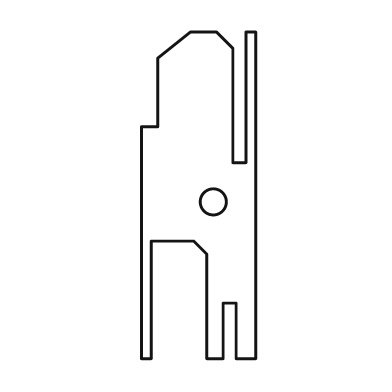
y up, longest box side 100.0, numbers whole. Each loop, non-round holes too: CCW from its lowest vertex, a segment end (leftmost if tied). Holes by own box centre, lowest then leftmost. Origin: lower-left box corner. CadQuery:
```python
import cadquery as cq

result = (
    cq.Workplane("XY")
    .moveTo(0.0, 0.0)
    .lineTo(3.0, 0.0)
    .lineTo(3.0, 36.0)
    .lineTo(16.0, 36.0)
    .lineTo(20.0, 32.0)
    .lineTo(20.0, 0.0)
    .lineTo(25.0, 0.0)
    .lineTo(25.0, 17.0)
    .lineTo(29.0, 17.0)
    .lineTo(29.0, 0.0)
    .lineTo(35.0, 0.0)
    .lineTo(35.0, 100.0)
    .lineTo(32.0, 100.0)
    .lineTo(32.0, 60.0)
    .lineTo(28.0, 60.0)
    .lineTo(28.0, 95.0)
    .lineTo(23.0, 100.0)
    .lineTo(15.0, 100.0)
    .lineTo(5.0, 92.0)
    .lineTo(5.0, 71.0)
    .lineTo(0.0, 71.0)
    .close()
    .moveTo(22.0, 48.0)
    .circle(4.0)
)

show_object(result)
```